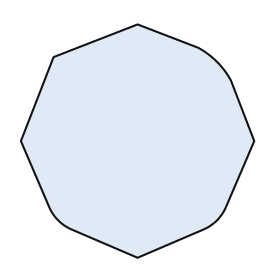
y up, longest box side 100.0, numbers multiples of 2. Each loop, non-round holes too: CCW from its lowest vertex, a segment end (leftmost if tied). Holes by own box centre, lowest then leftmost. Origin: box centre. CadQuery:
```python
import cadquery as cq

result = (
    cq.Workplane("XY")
    .moveTo(0.0, -50.0)
    .lineTo(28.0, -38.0)
    .threePointArc((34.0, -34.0), (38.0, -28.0))
    .lineTo(50.0, 0.0)
    .lineTo(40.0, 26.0)
    .threePointArc((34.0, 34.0), (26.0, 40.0))
    .lineTo(0.0, 50.0)
    .lineTo(-36.0, 36.0)
    .lineTo(-50.0, 0.0)
    .lineTo(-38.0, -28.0)
    .threePointArc((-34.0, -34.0), (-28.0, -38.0))
    .close()
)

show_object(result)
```